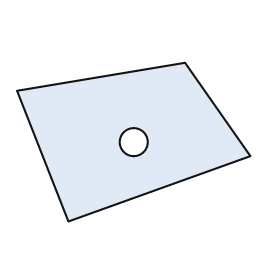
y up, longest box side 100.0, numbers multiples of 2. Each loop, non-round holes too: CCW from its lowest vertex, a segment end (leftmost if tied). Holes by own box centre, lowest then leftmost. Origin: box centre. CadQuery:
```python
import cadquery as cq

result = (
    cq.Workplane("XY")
    .moveTo(-28.0, -34.0)
    .lineTo(50.0, -6.0)
    .lineTo(22.0, 34.0)
    .lineTo(-50.0, 22.0)
    .close()
    .moveTo(0.0, 0.0)
    .circle(6.0)
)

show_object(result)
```